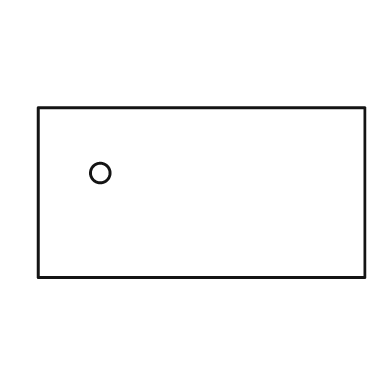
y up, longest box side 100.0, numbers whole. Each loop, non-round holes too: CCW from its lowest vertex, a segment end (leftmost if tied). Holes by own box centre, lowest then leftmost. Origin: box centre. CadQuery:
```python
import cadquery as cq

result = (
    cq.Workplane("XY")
    .moveTo(-50.0, -26.0)
    .lineTo(50.0, -26.0)
    .lineTo(50.0, 26.0)
    .lineTo(-50.0, 26.0)
    .close()
    .moveTo(-31.0, 6.0)
    .circle(3.0)
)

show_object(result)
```